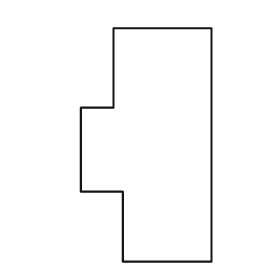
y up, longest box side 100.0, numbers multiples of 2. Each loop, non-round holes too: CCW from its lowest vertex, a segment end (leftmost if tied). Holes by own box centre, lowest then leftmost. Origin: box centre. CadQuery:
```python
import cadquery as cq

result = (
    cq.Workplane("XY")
    .moveTo(-10.0, -50.0)
    .lineTo(28.0, -50.0)
    .lineTo(28.0, 50.0)
    .lineTo(-14.0, 50.0)
    .lineTo(-14.0, 16.0)
    .lineTo(-28.0, 16.0)
    .lineTo(-28.0, -20.0)
    .lineTo(-10.0, -20.0)
    .close()
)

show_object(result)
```